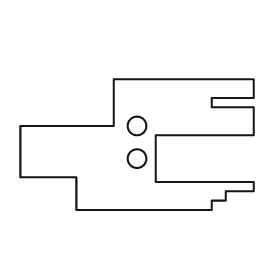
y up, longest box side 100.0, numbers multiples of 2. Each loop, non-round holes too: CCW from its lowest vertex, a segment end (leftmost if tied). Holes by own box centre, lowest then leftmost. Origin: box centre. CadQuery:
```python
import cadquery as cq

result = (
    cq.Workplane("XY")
    .moveTo(-26.0, -28.0)
    .lineTo(32.0, -28.0)
    .lineTo(32.0, -24.0)
    .lineTo(38.0, -24.0)
    .lineTo(38.0, -20.0)
    .lineTo(50.0, -20.0)
    .lineTo(50.0, -16.0)
    .lineTo(8.0, -16.0)
    .lineTo(8.0, 4.0)
    .lineTo(50.0, 4.0)
    .lineTo(50.0, 16.0)
    .lineTo(32.0, 16.0)
    .lineTo(32.0, 20.0)
    .lineTo(50.0, 20.0)
    .lineTo(50.0, 28.0)
    .lineTo(-10.0, 28.0)
    .lineTo(-10.0, 8.0)
    .lineTo(-50.0, 8.0)
    .lineTo(-50.0, -14.0)
    .lineTo(-26.0, -14.0)
    .close()
    .moveTo(0.0, -6.0)
    .circle(4.0)
    .moveTo(0.0, 8.0)
    .circle(4.0)
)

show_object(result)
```